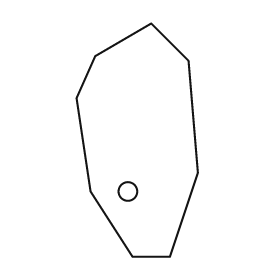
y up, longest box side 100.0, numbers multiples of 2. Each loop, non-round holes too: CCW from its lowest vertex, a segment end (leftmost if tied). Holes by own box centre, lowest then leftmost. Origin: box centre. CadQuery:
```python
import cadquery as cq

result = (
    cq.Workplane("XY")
    .moveTo(-2.0, -50.0)
    .lineTo(14.0, -50.0)
    .lineTo(26.0, -14.0)
    .lineTo(22.0, 34.0)
    .lineTo(6.0, 50.0)
    .lineTo(-18.0, 36.0)
    .lineTo(-26.0, 18.0)
    .lineTo(-20.0, -22.0)
    .close()
    .moveTo(-4.0, -22.0)
    .circle(4.0)
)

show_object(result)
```